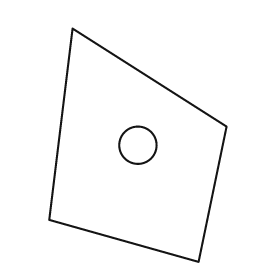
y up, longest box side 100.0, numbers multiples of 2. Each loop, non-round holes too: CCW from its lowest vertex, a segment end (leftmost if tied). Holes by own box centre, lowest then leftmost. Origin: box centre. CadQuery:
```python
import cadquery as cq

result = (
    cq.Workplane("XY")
    .moveTo(26.0, -50.0)
    .lineTo(38.0, 8.0)
    .lineTo(-28.0, 50.0)
    .lineTo(-38.0, -32.0)
    .close()
    .moveTo(0.0, 0.0)
    .circle(8.0)
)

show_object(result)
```